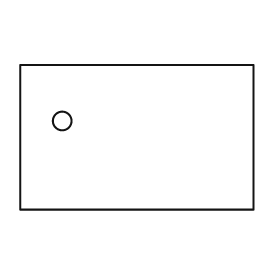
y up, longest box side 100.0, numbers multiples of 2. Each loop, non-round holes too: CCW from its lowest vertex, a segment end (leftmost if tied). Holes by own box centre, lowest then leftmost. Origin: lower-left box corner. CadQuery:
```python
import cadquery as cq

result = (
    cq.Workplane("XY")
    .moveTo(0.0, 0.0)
    .lineTo(100.0, 0.0)
    .lineTo(100.0, 62.0)
    .lineTo(0.0, 62.0)
    .close()
    .moveTo(18.0, 38.0)
    .circle(4.0)
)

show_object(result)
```